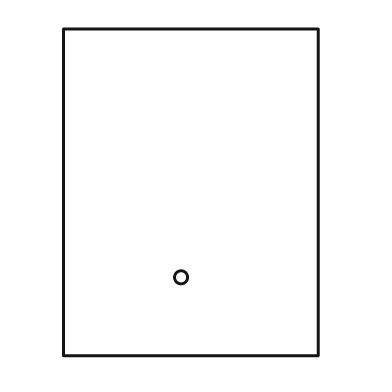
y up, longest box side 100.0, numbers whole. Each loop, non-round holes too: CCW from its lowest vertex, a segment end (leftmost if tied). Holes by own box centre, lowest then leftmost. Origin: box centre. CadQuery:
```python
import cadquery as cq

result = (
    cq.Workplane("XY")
    .moveTo(-39.0, -50.0)
    .lineTo(39.0, -50.0)
    .lineTo(39.0, 50.0)
    .lineTo(-39.0, 50.0)
    .close()
    .moveTo(-3.0, -26.0)
    .circle(2.0)
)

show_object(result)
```